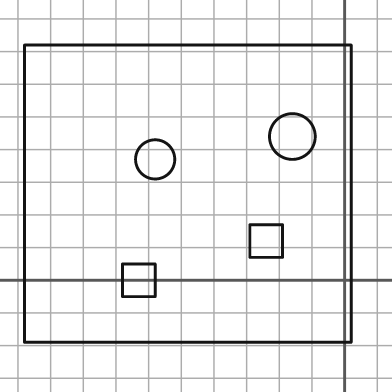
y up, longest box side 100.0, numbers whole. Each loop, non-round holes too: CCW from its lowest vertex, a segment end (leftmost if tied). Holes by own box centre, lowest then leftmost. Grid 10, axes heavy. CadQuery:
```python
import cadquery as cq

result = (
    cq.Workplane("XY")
    .moveTo(-98.0, -19.0)
    .lineTo(2.0, -19.0)
    .lineTo(2.0, 72.0)
    .lineTo(-98.0, 72.0)
    .close()
    .moveTo(-68.0, -5.0)
    .lineTo(-58.0, -5.0)
    .lineTo(-58.0, 5.0)
    .lineTo(-68.0, 5.0)
    .close()
    .moveTo(-29.0, 7.0)
    .lineTo(-19.0, 7.0)
    .lineTo(-19.0, 17.0)
    .lineTo(-29.0, 17.0)
    .close()
    .moveTo(-58.0, 37.0)
    .circle(6.0)
    .moveTo(-16.0, 44.0)
    .circle(7.0)
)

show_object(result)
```